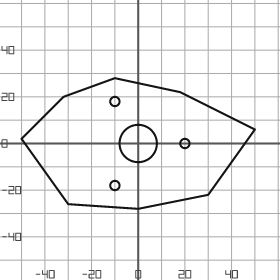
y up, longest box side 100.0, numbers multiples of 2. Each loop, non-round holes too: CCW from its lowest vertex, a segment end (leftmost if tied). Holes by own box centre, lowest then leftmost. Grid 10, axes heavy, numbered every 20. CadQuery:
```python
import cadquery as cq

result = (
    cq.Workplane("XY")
    .moveTo(0.0, -28.0)
    .lineTo(30.0, -22.0)
    .lineTo(50.0, 6.0)
    .lineTo(18.0, 22.0)
    .lineTo(-10.0, 28.0)
    .lineTo(-32.0, 20.0)
    .lineTo(-50.0, 2.0)
    .lineTo(-30.0, -26.0)
    .close()
    .moveTo(-10.0, -18.0)
    .circle(2.0)
    .moveTo(0.0, 0.0)
    .circle(8.0)
    .moveTo(20.0, 0.0)
    .circle(2.0)
    .moveTo(-10.0, 18.0)
    .circle(2.0)
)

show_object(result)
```